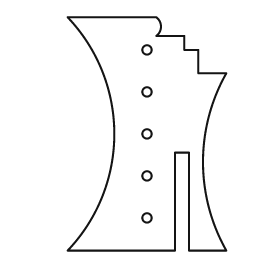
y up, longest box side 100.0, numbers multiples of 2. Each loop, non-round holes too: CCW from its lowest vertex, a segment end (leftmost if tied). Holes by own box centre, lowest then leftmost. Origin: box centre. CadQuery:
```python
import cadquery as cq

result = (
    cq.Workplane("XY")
    .moveTo(-34.0, -50.0)
    .lineTo(12.0, -50.0)
    .lineTo(12.0, -8.0)
    .lineTo(18.0, -8.0)
    .lineTo(18.0, -50.0)
    .lineTo(34.0, -50.0)
    .threePointArc((24.0, -12.0), (34.0, 26.0))
    .lineTo(22.0, 26.0)
    .lineTo(22.0, 36.0)
    .lineTo(16.0, 36.0)
    .lineTo(16.0, 42.0)
    .lineTo(4.0, 42.0)
    .threePointArc((6.0, 46.0), (4.0, 50.0))
    .lineTo(-34.0, 50.0)
    .threePointArc((-14.0, 0.0), (-34.0, -50.0))
    .close()
    .moveTo(0.0, -36.0)
    .circle(2.0)
    .moveTo(0.0, -18.0)
    .circle(2.0)
    .moveTo(0.0, 0.0)
    .circle(2.0)
    .moveTo(0.0, 18.0)
    .circle(2.0)
    .moveTo(0.0, 36.0)
    .circle(2.0)
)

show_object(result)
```